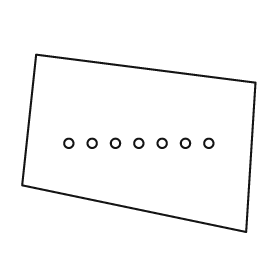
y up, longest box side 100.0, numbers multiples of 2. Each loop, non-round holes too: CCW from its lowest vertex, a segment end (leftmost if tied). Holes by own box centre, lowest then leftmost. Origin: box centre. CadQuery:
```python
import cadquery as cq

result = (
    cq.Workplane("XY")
    .moveTo(46.0, -38.0)
    .lineTo(50.0, 26.0)
    .lineTo(-44.0, 38.0)
    .lineTo(-50.0, -18.0)
    .close()
    .moveTo(-30.0, 0.0)
    .circle(2.0)
    .moveTo(-20.0, 0.0)
    .circle(2.0)
    .moveTo(-10.0, 0.0)
    .circle(2.0)
    .moveTo(0.0, 0.0)
    .circle(2.0)
    .moveTo(10.0, 0.0)
    .circle(2.0)
    .moveTo(20.0, 0.0)
    .circle(2.0)
    .moveTo(30.0, 0.0)
    .circle(2.0)
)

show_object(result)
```